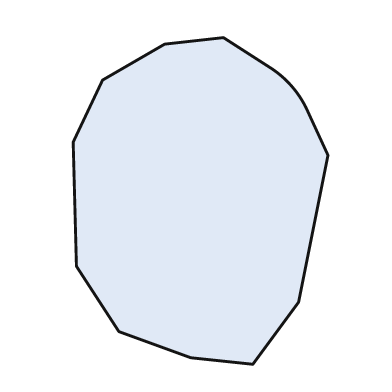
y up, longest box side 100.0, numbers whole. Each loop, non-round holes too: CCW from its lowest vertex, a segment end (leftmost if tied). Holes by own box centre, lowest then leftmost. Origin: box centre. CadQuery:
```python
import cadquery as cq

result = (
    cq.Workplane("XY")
    .moveTo(16.0, -50.0)
    .lineTo(30.0, -31.0)
    .lineTo(39.0, 14.0)
    .lineTo(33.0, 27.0)
    .threePointArc((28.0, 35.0), (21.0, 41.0))
    .lineTo(7.0, 50.0)
    .lineTo(-11.0, 48.0)
    .lineTo(-30.0, 37.0)
    .lineTo(-39.0, 18.0)
    .lineTo(-38.0, -20.0)
    .lineTo(-25.0, -40.0)
    .lineTo(-3.0, -48.0)
    .close()
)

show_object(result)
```